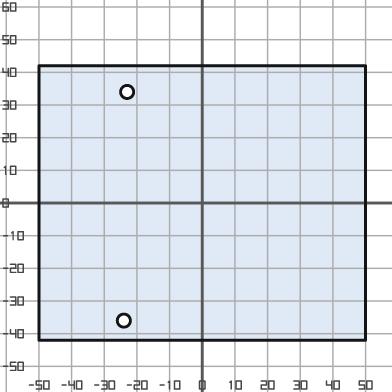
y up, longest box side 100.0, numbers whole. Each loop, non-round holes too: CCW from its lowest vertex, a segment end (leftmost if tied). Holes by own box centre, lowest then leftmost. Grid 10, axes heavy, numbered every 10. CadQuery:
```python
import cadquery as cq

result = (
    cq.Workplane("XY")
    .moveTo(-50.0, -42.0)
    .lineTo(50.0, -42.0)
    .lineTo(50.0, 42.0)
    .lineTo(-50.0, 42.0)
    .close()
    .moveTo(-24.0, -36.0)
    .circle(2.0)
    .moveTo(-23.0, 34.0)
    .circle(2.0)
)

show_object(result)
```